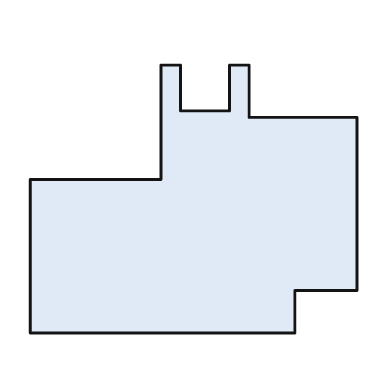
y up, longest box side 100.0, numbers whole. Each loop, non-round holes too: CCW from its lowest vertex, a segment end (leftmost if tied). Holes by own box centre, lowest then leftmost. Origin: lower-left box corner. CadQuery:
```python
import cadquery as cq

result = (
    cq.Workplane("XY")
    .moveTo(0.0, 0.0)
    .lineTo(81.0, 0.0)
    .lineTo(81.0, 13.0)
    .lineTo(100.0, 13.0)
    .lineTo(100.0, 66.0)
    .lineTo(67.0, 66.0)
    .lineTo(67.0, 82.0)
    .lineTo(61.0, 82.0)
    .lineTo(61.0, 68.0)
    .lineTo(46.0, 68.0)
    .lineTo(46.0, 82.0)
    .lineTo(40.0, 82.0)
    .lineTo(40.0, 47.0)
    .lineTo(0.0, 47.0)
    .close()
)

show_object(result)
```